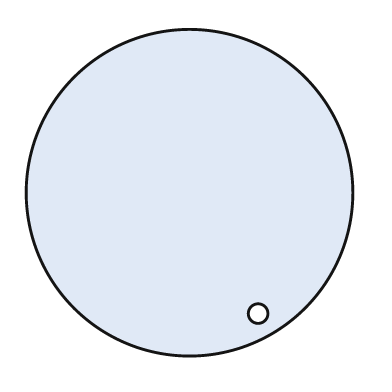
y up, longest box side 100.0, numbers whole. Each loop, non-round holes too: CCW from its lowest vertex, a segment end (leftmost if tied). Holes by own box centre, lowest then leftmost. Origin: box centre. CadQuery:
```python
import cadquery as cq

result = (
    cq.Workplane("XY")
    .moveTo(0.0, 0.0)
    .circle(50.0)
    .moveTo(21.0, -37.0)
    .circle(3.0)
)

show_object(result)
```